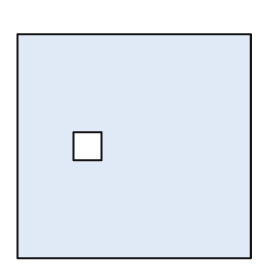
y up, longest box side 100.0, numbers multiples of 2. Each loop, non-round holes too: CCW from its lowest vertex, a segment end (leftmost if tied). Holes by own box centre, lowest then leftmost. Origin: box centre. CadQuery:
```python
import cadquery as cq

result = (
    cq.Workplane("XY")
    .moveTo(-50.0, -48.0)
    .lineTo(50.0, -48.0)
    .lineTo(50.0, 48.0)
    .lineTo(-50.0, 48.0)
    .close()
    .moveTo(-26.0, -6.0)
    .lineTo(-14.0, -6.0)
    .lineTo(-14.0, 6.0)
    .lineTo(-26.0, 6.0)
    .close()
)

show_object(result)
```